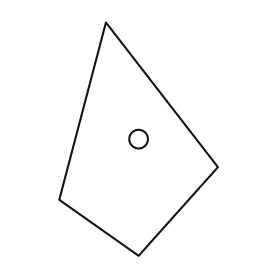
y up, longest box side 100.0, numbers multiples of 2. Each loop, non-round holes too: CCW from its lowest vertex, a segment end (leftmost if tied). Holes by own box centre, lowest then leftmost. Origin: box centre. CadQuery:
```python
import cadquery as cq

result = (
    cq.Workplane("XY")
    .moveTo(0.0, -50.0)
    .lineTo(34.0, -12.0)
    .lineTo(-14.0, 50.0)
    .lineTo(-34.0, -26.0)
    .close()
    .moveTo(0.0, 0.0)
    .circle(4.0)
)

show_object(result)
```